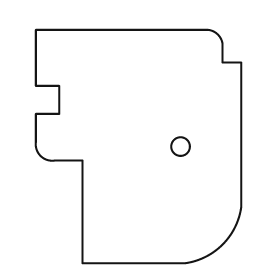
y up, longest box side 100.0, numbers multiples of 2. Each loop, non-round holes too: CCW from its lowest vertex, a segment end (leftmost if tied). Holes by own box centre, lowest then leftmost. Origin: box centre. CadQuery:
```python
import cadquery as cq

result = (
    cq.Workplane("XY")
    .moveTo(-24.0, -50.0)
    .lineTo(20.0, -50.0)
    .threePointArc((36.0, -42.0), (44.0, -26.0))
    .lineTo(44.0, 36.0)
    .lineTo(36.0, 36.0)
    .lineTo(36.0, 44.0)
    .threePointArc((34.0, 48.0), (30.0, 50.0))
    .lineTo(-44.0, 50.0)
    .lineTo(-44.0, 26.0)
    .lineTo(-34.0, 26.0)
    .lineTo(-34.0, 14.0)
    .lineTo(-44.0, 14.0)
    .lineTo(-44.0, 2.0)
    .threePointArc((-42.0, -4.0), (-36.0, -6.0))
    .lineTo(-24.0, -6.0)
    .close()
    .moveTo(18.0, 0.0)
    .circle(4.0)
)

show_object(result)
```